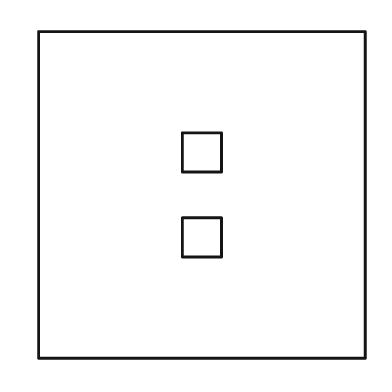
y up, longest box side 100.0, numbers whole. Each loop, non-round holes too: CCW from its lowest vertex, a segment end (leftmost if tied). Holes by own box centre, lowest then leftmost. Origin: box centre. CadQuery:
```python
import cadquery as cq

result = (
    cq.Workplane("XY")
    .moveTo(-50.0, -50.0)
    .lineTo(50.0, -50.0)
    .lineTo(50.0, 50.0)
    .lineTo(-50.0, 50.0)
    .close()
    .moveTo(-6.0, -19.0)
    .lineTo(6.0, -19.0)
    .lineTo(6.0, -7.0)
    .lineTo(-6.0, -7.0)
    .close()
    .moveTo(-6.0, 7.0)
    .lineTo(6.0, 7.0)
    .lineTo(6.0, 19.0)
    .lineTo(-6.0, 19.0)
    .close()
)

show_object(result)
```